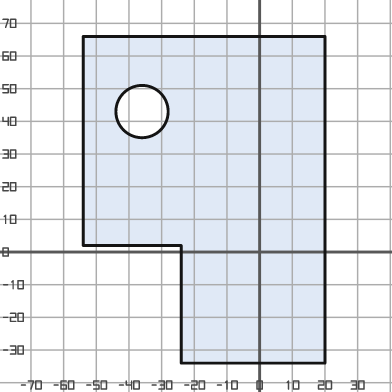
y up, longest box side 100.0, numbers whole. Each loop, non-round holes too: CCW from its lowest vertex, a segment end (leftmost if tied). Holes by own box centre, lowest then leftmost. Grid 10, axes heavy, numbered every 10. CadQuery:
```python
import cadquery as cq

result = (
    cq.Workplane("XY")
    .moveTo(-24.0, -34.0)
    .lineTo(20.0, -34.0)
    .lineTo(20.0, 66.0)
    .lineTo(-54.0, 66.0)
    .lineTo(-54.0, 2.0)
    .lineTo(-24.0, 2.0)
    .close()
    .moveTo(-36.0, 43.0)
    .circle(8.0)
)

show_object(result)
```